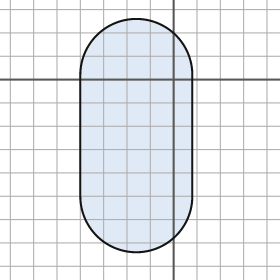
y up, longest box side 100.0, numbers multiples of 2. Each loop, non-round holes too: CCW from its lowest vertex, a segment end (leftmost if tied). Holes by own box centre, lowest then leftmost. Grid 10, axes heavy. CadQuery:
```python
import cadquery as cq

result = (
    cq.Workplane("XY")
    .moveTo(-40.0, -50.0)
    .threePointArc((-16.0, -74.0), (8.0, -50.0))
    .lineTo(8.0, 2.0)
    .threePointArc((-16.0, 26.0), (-40.0, 2.0))
    .close()
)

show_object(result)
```